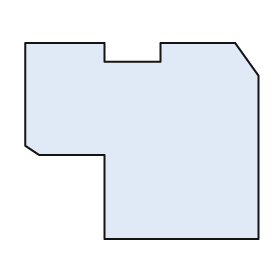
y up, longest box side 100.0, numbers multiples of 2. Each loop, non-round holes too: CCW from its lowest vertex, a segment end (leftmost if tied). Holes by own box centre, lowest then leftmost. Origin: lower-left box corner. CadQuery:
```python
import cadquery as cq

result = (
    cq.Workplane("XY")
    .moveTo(34.0, 0.0)
    .lineTo(100.0, 0.0)
    .lineTo(100.0, 70.0)
    .lineTo(90.0, 84.0)
    .lineTo(58.0, 84.0)
    .lineTo(58.0, 76.0)
    .lineTo(34.0, 76.0)
    .lineTo(34.0, 84.0)
    .lineTo(0.0, 84.0)
    .lineTo(0.0, 40.0)
    .lineTo(6.0, 36.0)
    .lineTo(34.0, 36.0)
    .close()
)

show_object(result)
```